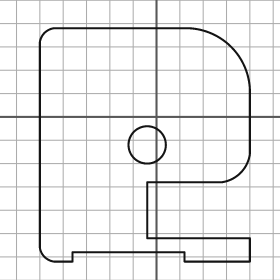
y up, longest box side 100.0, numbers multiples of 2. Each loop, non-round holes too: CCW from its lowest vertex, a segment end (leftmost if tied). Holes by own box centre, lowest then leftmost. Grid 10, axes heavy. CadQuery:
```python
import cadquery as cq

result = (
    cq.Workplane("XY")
    .moveTo(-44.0, -62.0)
    .lineTo(-36.0, -62.0)
    .lineTo(-36.0, -58.0)
    .lineTo(12.0, -58.0)
    .lineTo(12.0, -62.0)
    .lineTo(40.0, -62.0)
    .lineTo(40.0, -52.0)
    .lineTo(-4.0, -52.0)
    .lineTo(-4.0, -28.0)
    .lineTo(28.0, -28.0)
    .threePointArc((36.0, -24.0), (40.0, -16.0))
    .lineTo(40.0, 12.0)
    .threePointArc((32.0, 30.0), (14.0, 38.0))
    .lineTo(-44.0, 38.0)
    .threePointArc((-48.0, 36.0), (-50.0, 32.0))
    .lineTo(-50.0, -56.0)
    .threePointArc((-48.0, -60.0), (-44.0, -62.0))
    .close()
    .moveTo(-4.0, -12.0)
    .circle(8.0)
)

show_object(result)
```